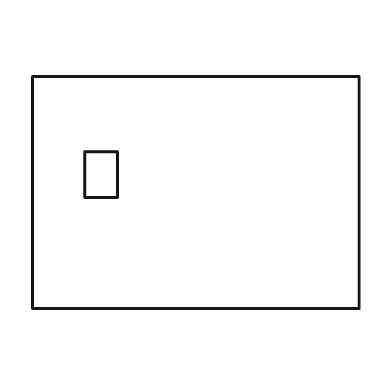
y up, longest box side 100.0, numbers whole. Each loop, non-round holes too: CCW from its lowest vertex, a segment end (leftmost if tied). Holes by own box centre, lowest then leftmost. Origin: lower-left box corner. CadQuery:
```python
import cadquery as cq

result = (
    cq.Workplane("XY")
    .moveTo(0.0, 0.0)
    .lineTo(100.0, 0.0)
    .lineTo(100.0, 71.0)
    .lineTo(0.0, 71.0)
    .close()
    .moveTo(16.0, 34.0)
    .lineTo(26.0, 34.0)
    .lineTo(26.0, 48.0)
    .lineTo(16.0, 48.0)
    .close()
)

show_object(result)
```